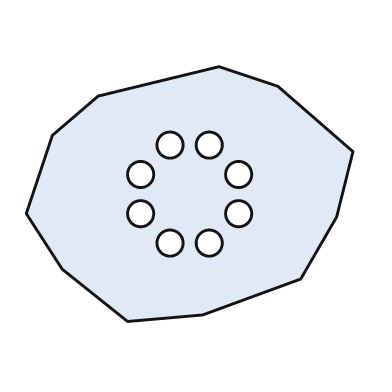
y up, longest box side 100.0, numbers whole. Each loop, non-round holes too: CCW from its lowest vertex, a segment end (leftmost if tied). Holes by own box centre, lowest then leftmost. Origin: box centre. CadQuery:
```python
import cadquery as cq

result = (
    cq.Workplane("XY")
    .moveTo(-19.0, -39.0)
    .lineTo(4.0, -37.0)
    .lineTo(34.0, -26.0)
    .lineTo(45.0, -7.0)
    .lineTo(50.0, 13.0)
    .lineTo(27.0, 33.0)
    .lineTo(9.0, 39.0)
    .lineTo(-28.0, 30.0)
    .lineTo(-42.0, 18.0)
    .lineTo(-50.0, -6.0)
    .lineTo(-39.0, -23.0)
    .close()
    .moveTo(-6.0, -15.0)
    .circle(4.0)
    .moveTo(6.0, -15.0)
    .circle(4.0)
    .moveTo(-15.0, -6.0)
    .circle(4.0)
    .moveTo(15.0, -6.0)
    .circle(4.0)
    .moveTo(-15.0, 6.0)
    .circle(4.0)
    .moveTo(15.0, 6.0)
    .circle(4.0)
    .moveTo(-6.0, 15.0)
    .circle(4.0)
    .moveTo(6.0, 15.0)
    .circle(4.0)
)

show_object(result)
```